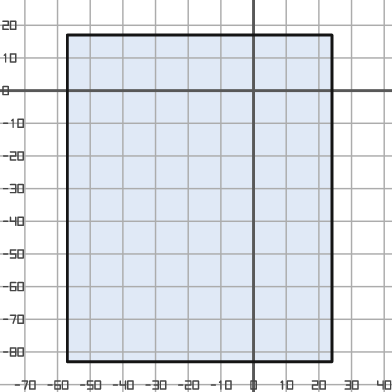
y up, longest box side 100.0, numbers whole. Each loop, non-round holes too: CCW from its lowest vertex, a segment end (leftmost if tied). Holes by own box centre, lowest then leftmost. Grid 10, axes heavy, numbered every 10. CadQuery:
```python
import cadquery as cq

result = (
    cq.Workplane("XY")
    .moveTo(-57.0, -83.0)
    .lineTo(24.0, -83.0)
    .lineTo(24.0, 17.0)
    .lineTo(-57.0, 17.0)
    .close()
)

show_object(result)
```